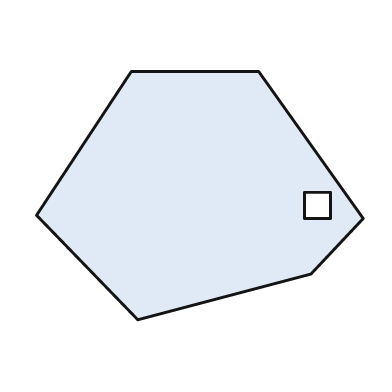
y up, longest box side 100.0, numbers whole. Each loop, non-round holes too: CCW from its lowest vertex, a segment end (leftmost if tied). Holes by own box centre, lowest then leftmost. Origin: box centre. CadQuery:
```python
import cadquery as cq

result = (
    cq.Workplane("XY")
    .moveTo(-19.0, -38.0)
    .lineTo(34.0, -24.0)
    .lineTo(50.0, -7.0)
    .lineTo(18.0, 38.0)
    .lineTo(-21.0, 38.0)
    .lineTo(-50.0, -6.0)
    .close()
    .moveTo(32.0, -7.0)
    .lineTo(40.0, -7.0)
    .lineTo(40.0, 1.0)
    .lineTo(32.0, 1.0)
    .close()
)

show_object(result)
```